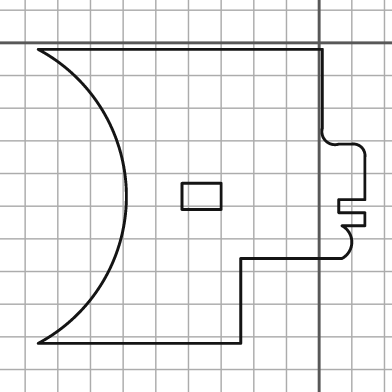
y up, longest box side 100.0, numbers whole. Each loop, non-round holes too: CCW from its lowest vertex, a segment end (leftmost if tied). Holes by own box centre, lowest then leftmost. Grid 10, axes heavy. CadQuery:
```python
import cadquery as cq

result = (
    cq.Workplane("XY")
    .moveTo(-86.0, -92.0)
    .lineTo(-24.0, -92.0)
    .lineTo(-24.0, -66.0)
    .lineTo(7.0, -66.0)
    .threePointArc((10.0, -61.0), (7.0, -56.0))
    .lineTo(14.0, -56.0)
    .lineTo(14.0, -52.0)
    .lineTo(6.0, -52.0)
    .lineTo(6.0, -48.0)
    .lineTo(14.0, -48.0)
    .lineTo(14.0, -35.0)
    .threePointArc((13.0, -32.0), (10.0, -31.0))
    .lineTo(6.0, -31.0)
    .threePointArc((2.0, -30.0), (1.0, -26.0))
    .lineTo(1.0, -2.0)
    .lineTo(-86.0, -2.0)
    .threePointArc((-59.0, -47.0), (-86.0, -92.0))
    .close()
    .moveTo(-42.0, -51.0)
    .lineTo(-30.0, -51.0)
    .lineTo(-30.0, -43.0)
    .lineTo(-42.0, -43.0)
    .close()
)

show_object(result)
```